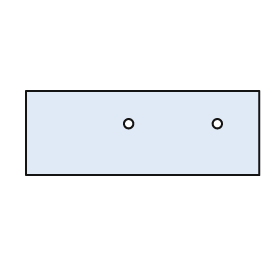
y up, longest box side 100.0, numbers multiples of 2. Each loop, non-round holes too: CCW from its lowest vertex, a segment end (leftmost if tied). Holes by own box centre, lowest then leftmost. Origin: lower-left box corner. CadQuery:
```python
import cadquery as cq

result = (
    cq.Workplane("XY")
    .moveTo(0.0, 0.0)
    .lineTo(100.0, 0.0)
    .lineTo(100.0, 36.0)
    .lineTo(0.0, 36.0)
    .close()
    .moveTo(44.0, 22.0)
    .circle(2.0)
    .moveTo(82.0, 22.0)
    .circle(2.0)
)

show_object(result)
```